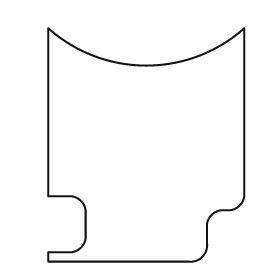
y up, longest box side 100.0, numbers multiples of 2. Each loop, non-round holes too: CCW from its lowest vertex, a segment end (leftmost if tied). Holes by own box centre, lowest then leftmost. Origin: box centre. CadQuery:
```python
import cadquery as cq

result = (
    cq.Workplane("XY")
    .moveTo(-42.0, -50.0)
    .lineTo(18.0, -50.0)
    .threePointArc((24.0, -48.0), (26.0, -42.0))
    .lineTo(26.0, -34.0)
    .threePointArc((28.0, -30.0), (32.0, -28.0))
    .lineTo(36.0, -28.0)
    .threePointArc((40.0, -26.0), (42.0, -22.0))
    .lineTo(42.0, 50.0)
    .threePointArc((0.0, 34.0), (-42.0, 50.0))
    .lineTo(-42.0, -22.0)
    .lineTo(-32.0, -22.0)
    .threePointArc((-28.0, -24.0), (-26.0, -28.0))
    .lineTo(-26.0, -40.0)
    .threePointArc((-28.0, -44.0), (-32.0, -46.0))
    .lineTo(-42.0, -46.0)
    .close()
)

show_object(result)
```